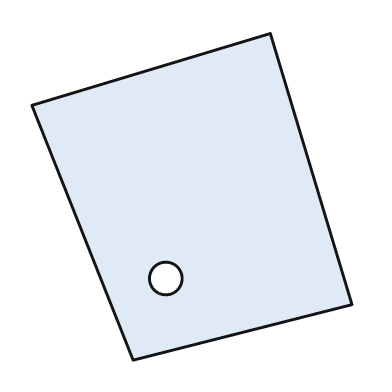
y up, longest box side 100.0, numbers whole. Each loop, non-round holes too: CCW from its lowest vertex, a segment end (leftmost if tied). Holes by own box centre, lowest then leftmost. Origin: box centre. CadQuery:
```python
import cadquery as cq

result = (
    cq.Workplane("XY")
    .moveTo(-18.0, -50.0)
    .lineTo(49.0, -33.0)
    .lineTo(24.0, 50.0)
    .lineTo(-49.0, 28.0)
    .close()
    .moveTo(-8.0, -25.0)
    .circle(5.0)
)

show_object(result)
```